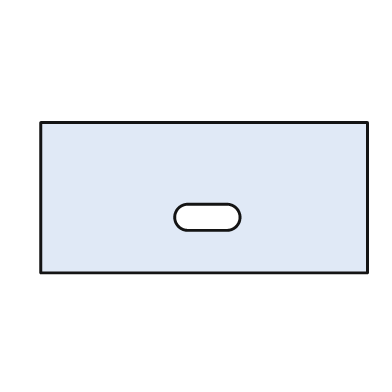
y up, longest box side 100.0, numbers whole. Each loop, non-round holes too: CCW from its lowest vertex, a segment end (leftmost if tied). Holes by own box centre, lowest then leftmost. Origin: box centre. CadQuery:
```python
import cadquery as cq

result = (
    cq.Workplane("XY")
    .moveTo(-50.0, -23.0)
    .lineTo(50.0, -23.0)
    .lineTo(50.0, 23.0)
    .lineTo(-50.0, 23.0)
    .close()
    .moveTo(-5.0, -10.0)
    .lineTo(7.0, -10.0)
    .threePointArc((11.0, -6.0), (7.0, -2.0))
    .lineTo(-5.0, -2.0)
    .threePointArc((-9.0, -6.0), (-5.0, -10.0))
    .close()
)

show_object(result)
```